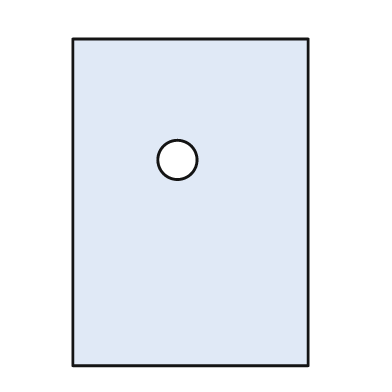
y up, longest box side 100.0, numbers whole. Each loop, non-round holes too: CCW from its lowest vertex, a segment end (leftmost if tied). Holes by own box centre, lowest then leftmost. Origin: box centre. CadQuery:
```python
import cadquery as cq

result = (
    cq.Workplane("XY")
    .moveTo(-36.0, -50.0)
    .lineTo(36.0, -50.0)
    .lineTo(36.0, 50.0)
    .lineTo(-36.0, 50.0)
    .close()
    .moveTo(-4.0, 13.0)
    .circle(6.0)
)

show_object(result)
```